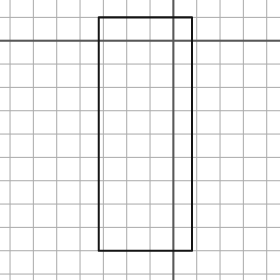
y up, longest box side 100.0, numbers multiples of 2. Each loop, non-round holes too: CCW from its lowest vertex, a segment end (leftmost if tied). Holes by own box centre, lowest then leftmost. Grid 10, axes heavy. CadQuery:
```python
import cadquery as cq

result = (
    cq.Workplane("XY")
    .moveTo(-32.0, -90.0)
    .lineTo(8.0, -90.0)
    .lineTo(8.0, 10.0)
    .lineTo(-32.0, 10.0)
    .close()
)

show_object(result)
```